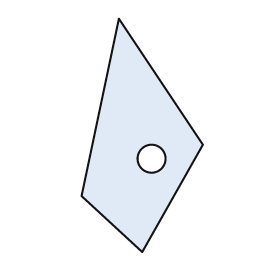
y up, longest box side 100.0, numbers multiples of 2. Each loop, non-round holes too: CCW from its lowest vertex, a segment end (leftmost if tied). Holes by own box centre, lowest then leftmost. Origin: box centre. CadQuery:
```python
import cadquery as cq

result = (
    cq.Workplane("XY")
    .moveTo(0.0, -50.0)
    .lineTo(26.0, -4.0)
    .lineTo(-10.0, 50.0)
    .lineTo(-26.0, -26.0)
    .close()
    .moveTo(4.0, -10.0)
    .circle(6.0)
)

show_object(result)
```